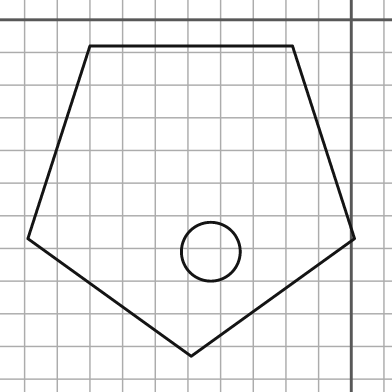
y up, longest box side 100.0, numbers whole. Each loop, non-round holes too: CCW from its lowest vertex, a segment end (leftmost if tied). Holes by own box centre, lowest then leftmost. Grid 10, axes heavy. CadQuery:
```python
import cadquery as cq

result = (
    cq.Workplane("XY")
    .moveTo(-49.0, -103.0)
    .lineTo(1.0, -67.0)
    .lineTo(-18.0, -8.0)
    .lineTo(-80.0, -8.0)
    .lineTo(-99.0, -67.0)
    .close()
    .moveTo(-43.0, -71.0)
    .circle(9.0)
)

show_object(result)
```